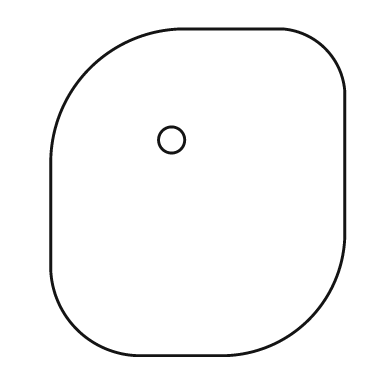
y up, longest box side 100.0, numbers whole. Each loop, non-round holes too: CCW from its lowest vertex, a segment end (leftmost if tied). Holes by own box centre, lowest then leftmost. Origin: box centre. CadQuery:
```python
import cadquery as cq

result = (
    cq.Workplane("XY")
    .moveTo(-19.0, -50.0)
    .lineTo(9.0, -50.0)
    .threePointArc((34.0, -39.0), (45.0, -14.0))
    .lineTo(45.0, 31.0)
    .threePointArc((39.0, 44.0), (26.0, 50.0))
    .lineTo(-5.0, 50.0)
    .threePointArc((-33.0, 38.0), (-45.0, 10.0))
    .lineTo(-45.0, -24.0)
    .threePointArc((-37.0, -42.0), (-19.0, -50.0))
    .close()
    .moveTo(-8.0, 16.0)
    .circle(4.0)
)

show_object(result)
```